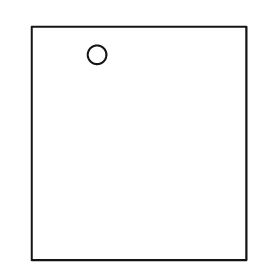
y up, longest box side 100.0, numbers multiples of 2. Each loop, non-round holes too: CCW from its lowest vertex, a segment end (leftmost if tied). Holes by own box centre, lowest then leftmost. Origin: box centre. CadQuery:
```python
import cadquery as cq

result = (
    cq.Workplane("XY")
    .moveTo(-46.0, -50.0)
    .lineTo(46.0, -50.0)
    .lineTo(46.0, 50.0)
    .lineTo(-46.0, 50.0)
    .close()
    .moveTo(-18.0, 38.0)
    .circle(4.0)
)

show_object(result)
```